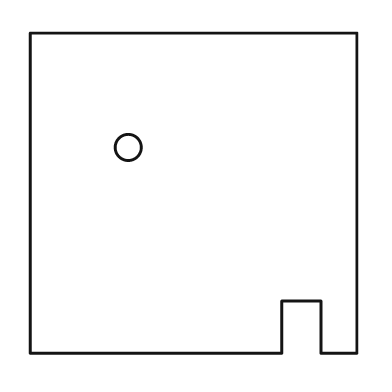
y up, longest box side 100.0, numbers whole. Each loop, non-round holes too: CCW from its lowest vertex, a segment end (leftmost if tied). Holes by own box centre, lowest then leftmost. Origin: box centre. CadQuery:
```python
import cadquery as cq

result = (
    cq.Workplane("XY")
    .moveTo(-50.0, -49.0)
    .lineTo(27.0, -49.0)
    .lineTo(27.0, -33.0)
    .lineTo(39.0, -33.0)
    .lineTo(39.0, -49.0)
    .lineTo(50.0, -49.0)
    .lineTo(50.0, 49.0)
    .lineTo(-50.0, 49.0)
    .close()
    .moveTo(-20.0, 14.0)
    .circle(4.0)
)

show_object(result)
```